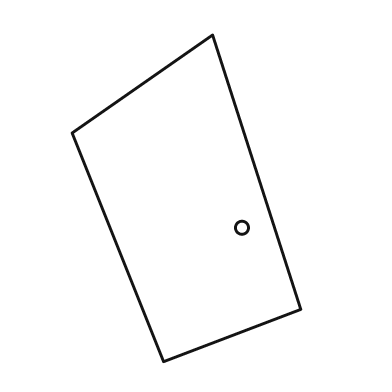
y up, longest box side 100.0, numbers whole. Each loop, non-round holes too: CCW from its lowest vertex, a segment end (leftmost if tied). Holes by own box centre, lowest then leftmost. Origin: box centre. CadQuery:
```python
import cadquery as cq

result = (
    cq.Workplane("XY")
    .moveTo(-7.0, -50.0)
    .lineTo(35.0, -34.0)
    .lineTo(8.0, 50.0)
    .lineTo(-35.0, 20.0)
    .close()
    .moveTo(17.0, -9.0)
    .circle(2.0)
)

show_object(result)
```